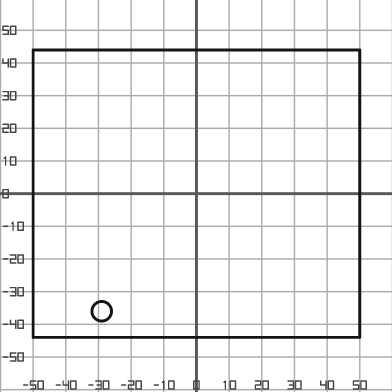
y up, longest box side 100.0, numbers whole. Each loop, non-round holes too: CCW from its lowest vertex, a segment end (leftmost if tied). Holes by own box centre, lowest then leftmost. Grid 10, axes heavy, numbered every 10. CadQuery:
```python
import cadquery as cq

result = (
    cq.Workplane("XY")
    .moveTo(-50.0, -44.0)
    .lineTo(50.0, -44.0)
    .lineTo(50.0, 44.0)
    .lineTo(-50.0, 44.0)
    .close()
    .moveTo(-29.0, -36.0)
    .circle(3.0)
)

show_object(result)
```